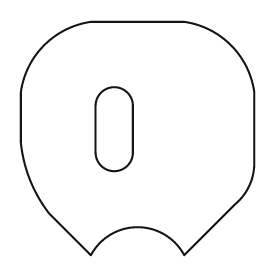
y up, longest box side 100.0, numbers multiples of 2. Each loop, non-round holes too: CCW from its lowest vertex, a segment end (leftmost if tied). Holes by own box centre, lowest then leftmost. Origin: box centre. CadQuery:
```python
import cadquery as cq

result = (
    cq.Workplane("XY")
    .moveTo(-20.0, -50.0)
    .threePointArc((0.0, -38.0), (20.0, -50.0))
    .lineTo(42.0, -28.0)
    .threePointArc((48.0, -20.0), (50.0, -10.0))
    .lineTo(50.0, 20.0)
    .threePointArc((40.0, 40.0), (20.0, 50.0))
    .lineTo(-20.0, 50.0)
    .threePointArc((-40.0, 40.0), (-50.0, 20.0))
    .lineTo(-50.0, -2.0)
    .threePointArc((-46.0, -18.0), (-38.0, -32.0))
    .close()
    .moveTo(-18.0, -6.0)
    .threePointArc((-10.0, -14.0), (-2.0, -6.0))
    .lineTo(-2.0, 14.0)
    .threePointArc((-10.0, 22.0), (-18.0, 14.0))
    .close()
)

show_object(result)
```